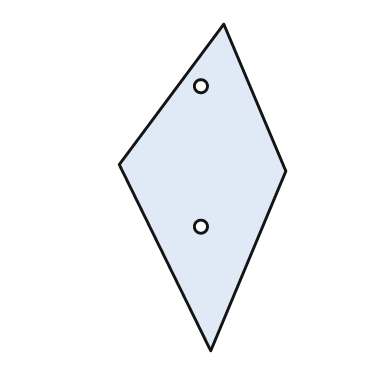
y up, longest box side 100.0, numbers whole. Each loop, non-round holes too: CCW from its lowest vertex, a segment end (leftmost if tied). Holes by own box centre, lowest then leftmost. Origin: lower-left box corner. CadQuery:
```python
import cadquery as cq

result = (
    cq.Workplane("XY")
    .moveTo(28.0, 0.0)
    .lineTo(51.0, 55.0)
    .lineTo(32.0, 100.0)
    .lineTo(0.0, 57.0)
    .close()
    .moveTo(25.0, 38.0)
    .circle(2.0)
    .moveTo(25.0, 81.0)
    .circle(2.0)
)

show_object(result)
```